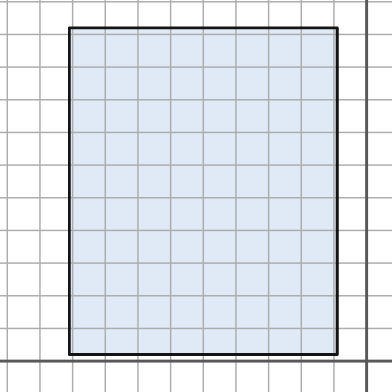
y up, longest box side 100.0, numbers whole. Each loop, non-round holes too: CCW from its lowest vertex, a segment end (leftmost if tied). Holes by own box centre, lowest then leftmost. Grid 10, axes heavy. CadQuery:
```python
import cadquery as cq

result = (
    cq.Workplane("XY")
    .moveTo(-91.0, 2.0)
    .lineTo(-9.0, 2.0)
    .lineTo(-9.0, 102.0)
    .lineTo(-91.0, 102.0)
    .close()
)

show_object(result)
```